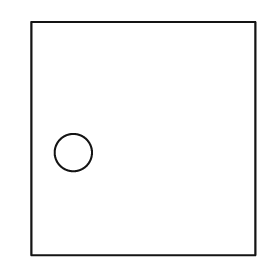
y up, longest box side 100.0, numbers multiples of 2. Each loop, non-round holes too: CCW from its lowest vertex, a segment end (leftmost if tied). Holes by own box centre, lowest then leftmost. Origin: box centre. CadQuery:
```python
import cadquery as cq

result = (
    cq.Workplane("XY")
    .moveTo(-48.0, -50.0)
    .lineTo(48.0, -50.0)
    .lineTo(48.0, 50.0)
    .lineTo(-48.0, 50.0)
    .close()
    .moveTo(-30.0, -6.0)
    .circle(8.0)
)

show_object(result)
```